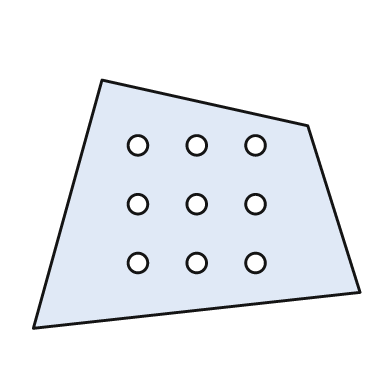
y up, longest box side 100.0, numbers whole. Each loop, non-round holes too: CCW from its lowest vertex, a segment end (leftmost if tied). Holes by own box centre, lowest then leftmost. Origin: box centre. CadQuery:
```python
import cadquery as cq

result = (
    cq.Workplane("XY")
    .moveTo(-50.0, -38.0)
    .lineTo(50.0, -27.0)
    .lineTo(34.0, 24.0)
    .lineTo(-29.0, 38.0)
    .close()
    .moveTo(-18.0, -18.0)
    .circle(3.0)
    .moveTo(0.0, -18.0)
    .circle(3.0)
    .moveTo(18.0, -18.0)
    .circle(3.0)
    .moveTo(-18.0, 0.0)
    .circle(3.0)
    .moveTo(0.0, 0.0)
    .circle(3.0)
    .moveTo(18.0, 0.0)
    .circle(3.0)
    .moveTo(-18.0, 18.0)
    .circle(3.0)
    .moveTo(0.0, 18.0)
    .circle(3.0)
    .moveTo(18.0, 18.0)
    .circle(3.0)
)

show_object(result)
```